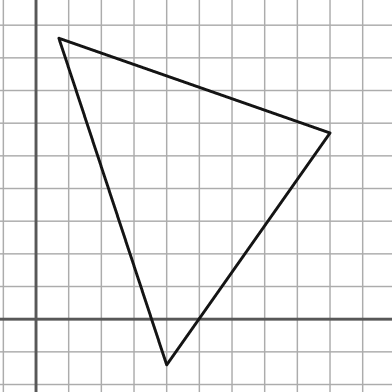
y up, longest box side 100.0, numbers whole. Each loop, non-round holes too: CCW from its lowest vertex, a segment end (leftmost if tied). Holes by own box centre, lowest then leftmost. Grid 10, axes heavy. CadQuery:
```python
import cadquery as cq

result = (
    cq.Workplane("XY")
    .moveTo(40.0, -14.0)
    .lineTo(90.0, 57.0)
    .lineTo(7.0, 86.0)
    .close()
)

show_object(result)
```